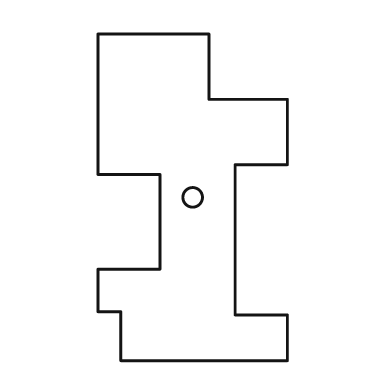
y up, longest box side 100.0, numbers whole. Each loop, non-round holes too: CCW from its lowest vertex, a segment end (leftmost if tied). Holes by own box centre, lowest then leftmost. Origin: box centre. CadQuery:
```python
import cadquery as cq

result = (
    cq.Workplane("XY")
    .moveTo(-22.0, -50.0)
    .lineTo(29.0, -50.0)
    .lineTo(29.0, -36.0)
    .lineTo(13.0, -36.0)
    .lineTo(13.0, 10.0)
    .lineTo(29.0, 10.0)
    .lineTo(29.0, 30.0)
    .lineTo(5.0, 30.0)
    .lineTo(5.0, 50.0)
    .lineTo(-29.0, 50.0)
    .lineTo(-29.0, 7.0)
    .lineTo(-10.0, 7.0)
    .lineTo(-10.0, -22.0)
    .lineTo(-29.0, -22.0)
    .lineTo(-29.0, -35.0)
    .lineTo(-22.0, -35.0)
    .close()
    .moveTo(0.0, 0.0)
    .circle(3.0)
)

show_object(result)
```